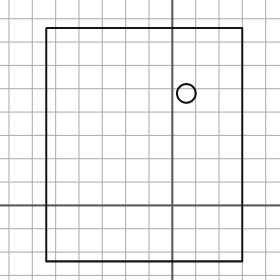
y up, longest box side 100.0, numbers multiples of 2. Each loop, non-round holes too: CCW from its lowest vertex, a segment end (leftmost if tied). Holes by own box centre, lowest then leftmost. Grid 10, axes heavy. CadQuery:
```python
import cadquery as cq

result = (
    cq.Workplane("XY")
    .moveTo(-54.0, -24.0)
    .lineTo(30.0, -24.0)
    .lineTo(30.0, 76.0)
    .lineTo(-54.0, 76.0)
    .close()
    .moveTo(6.0, 48.0)
    .circle(4.0)
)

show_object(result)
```